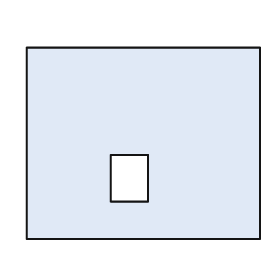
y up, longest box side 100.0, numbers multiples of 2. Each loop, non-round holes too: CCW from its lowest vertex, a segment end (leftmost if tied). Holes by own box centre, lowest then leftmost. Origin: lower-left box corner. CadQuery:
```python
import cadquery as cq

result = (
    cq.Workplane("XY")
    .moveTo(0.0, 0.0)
    .lineTo(100.0, 0.0)
    .lineTo(100.0, 82.0)
    .lineTo(0.0, 82.0)
    .close()
    .moveTo(36.0, 16.0)
    .lineTo(52.0, 16.0)
    .lineTo(52.0, 36.0)
    .lineTo(36.0, 36.0)
    .close()
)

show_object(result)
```